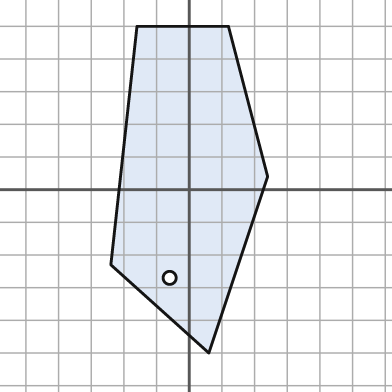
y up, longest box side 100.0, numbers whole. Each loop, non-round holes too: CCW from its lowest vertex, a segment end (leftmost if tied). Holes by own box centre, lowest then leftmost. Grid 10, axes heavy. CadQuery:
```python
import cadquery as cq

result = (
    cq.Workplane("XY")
    .moveTo(6.0, -50.0)
    .lineTo(24.0, 4.0)
    .lineTo(12.0, 50.0)
    .lineTo(-16.0, 50.0)
    .lineTo(-24.0, -23.0)
    .close()
    .moveTo(-6.0, -27.0)
    .circle(2.0)
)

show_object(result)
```